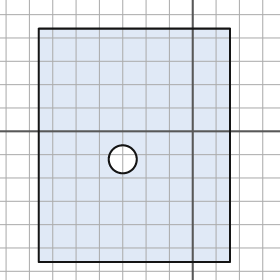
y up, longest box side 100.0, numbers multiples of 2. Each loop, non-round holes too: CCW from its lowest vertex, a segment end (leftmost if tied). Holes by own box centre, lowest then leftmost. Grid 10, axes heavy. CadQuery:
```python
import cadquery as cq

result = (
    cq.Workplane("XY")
    .moveTo(-66.0, -56.0)
    .lineTo(16.0, -56.0)
    .lineTo(16.0, 44.0)
    .lineTo(-66.0, 44.0)
    .close()
    .moveTo(-30.0, -12.0)
    .circle(6.0)
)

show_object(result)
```